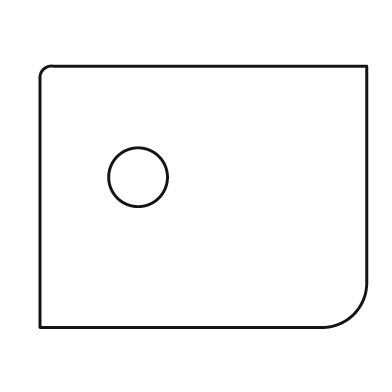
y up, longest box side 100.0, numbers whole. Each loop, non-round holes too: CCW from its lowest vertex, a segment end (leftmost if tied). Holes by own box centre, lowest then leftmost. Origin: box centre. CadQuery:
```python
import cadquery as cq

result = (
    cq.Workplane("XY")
    .moveTo(-50.0, -40.0)
    .lineTo(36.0, -40.0)
    .threePointArc((46.0, -36.0), (50.0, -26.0))
    .lineTo(50.0, 40.0)
    .lineTo(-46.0, 40.0)
    .threePointArc((-49.0, 39.0), (-50.0, 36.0))
    .close()
    .moveTo(-20.0, 6.0)
    .circle(9.0)
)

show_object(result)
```